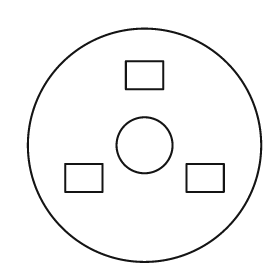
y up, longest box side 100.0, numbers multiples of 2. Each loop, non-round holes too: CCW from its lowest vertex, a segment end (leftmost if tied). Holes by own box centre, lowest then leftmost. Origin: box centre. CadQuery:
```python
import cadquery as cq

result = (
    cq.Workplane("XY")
    .moveTo(0.0, 0.0)
    .circle(50.0)
    .moveTo(-34.0, -20.0)
    .lineTo(-18.0, -20.0)
    .lineTo(-18.0, -8.0)
    .lineTo(-34.0, -8.0)
    .close()
    .moveTo(18.0, -20.0)
    .lineTo(34.0, -20.0)
    .lineTo(34.0, -8.0)
    .lineTo(18.0, -8.0)
    .close()
    .moveTo(0.0, 0.0)
    .circle(12.0)
    .moveTo(-8.0, 24.0)
    .lineTo(8.0, 24.0)
    .lineTo(8.0, 36.0)
    .lineTo(-8.0, 36.0)
    .close()
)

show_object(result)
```